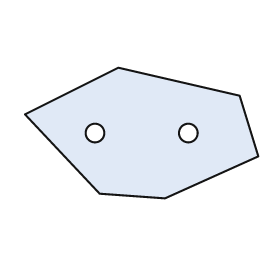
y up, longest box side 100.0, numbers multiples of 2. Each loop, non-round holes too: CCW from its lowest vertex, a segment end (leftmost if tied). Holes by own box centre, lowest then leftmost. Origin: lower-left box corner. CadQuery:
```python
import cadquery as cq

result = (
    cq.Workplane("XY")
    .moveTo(60.0, 0.0)
    .lineTo(100.0, 18.0)
    .lineTo(92.0, 44.0)
    .lineTo(40.0, 56.0)
    .lineTo(0.0, 36.0)
    .lineTo(32.0, 2.0)
    .close()
    .moveTo(30.0, 28.0)
    .circle(4.0)
    .moveTo(70.0, 28.0)
    .circle(4.0)
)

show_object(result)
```